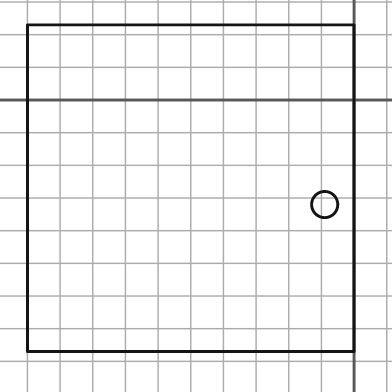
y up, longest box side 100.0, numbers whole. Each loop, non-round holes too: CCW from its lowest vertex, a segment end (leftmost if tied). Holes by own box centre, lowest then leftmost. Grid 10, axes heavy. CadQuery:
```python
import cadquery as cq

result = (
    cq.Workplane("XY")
    .moveTo(-100.0, -77.0)
    .lineTo(0.0, -77.0)
    .lineTo(0.0, 23.0)
    .lineTo(-100.0, 23.0)
    .close()
    .moveTo(-9.0, -32.0)
    .circle(4.0)
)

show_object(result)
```